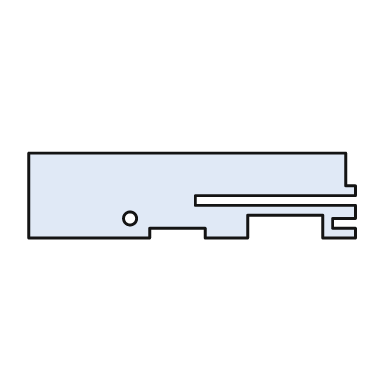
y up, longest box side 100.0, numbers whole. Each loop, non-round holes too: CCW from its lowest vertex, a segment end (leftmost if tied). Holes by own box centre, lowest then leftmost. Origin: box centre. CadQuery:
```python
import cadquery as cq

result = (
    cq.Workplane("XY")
    .moveTo(-50.0, -13.0)
    .lineTo(-13.0, -13.0)
    .lineTo(-13.0, -10.0)
    .lineTo(4.0, -10.0)
    .lineTo(4.0, -13.0)
    .lineTo(17.0, -13.0)
    .lineTo(17.0, -6.0)
    .lineTo(40.0, -6.0)
    .lineTo(40.0, -13.0)
    .lineTo(50.0, -13.0)
    .lineTo(50.0, -10.0)
    .lineTo(43.0, -10.0)
    .lineTo(43.0, -7.0)
    .lineTo(50.0, -7.0)
    .lineTo(50.0, -3.0)
    .lineTo(1.0, -3.0)
    .lineTo(1.0, 0.0)
    .lineTo(50.0, 0.0)
    .lineTo(50.0, 3.0)
    .lineTo(47.0, 3.0)
    .lineTo(47.0, 13.0)
    .lineTo(-50.0, 13.0)
    .close()
    .moveTo(-19.0, -7.0)
    .circle(2.0)
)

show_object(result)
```